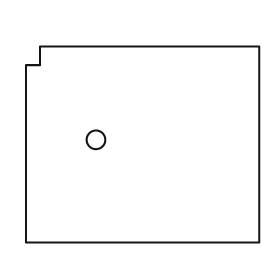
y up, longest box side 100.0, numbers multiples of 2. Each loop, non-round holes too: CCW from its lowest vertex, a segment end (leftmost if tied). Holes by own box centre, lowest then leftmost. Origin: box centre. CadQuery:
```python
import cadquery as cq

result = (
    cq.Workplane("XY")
    .moveTo(-50.0, -42.0)
    .lineTo(50.0, -42.0)
    .lineTo(50.0, 42.0)
    .lineTo(-44.0, 42.0)
    .lineTo(-44.0, 34.0)
    .lineTo(-50.0, 34.0)
    .close()
    .moveTo(-20.0, 2.0)
    .circle(4.0)
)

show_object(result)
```